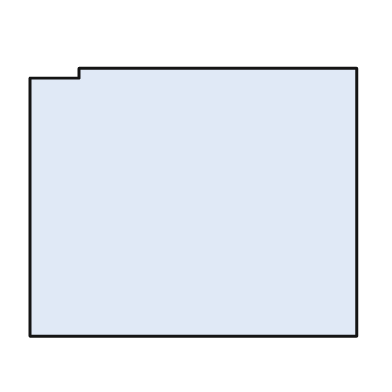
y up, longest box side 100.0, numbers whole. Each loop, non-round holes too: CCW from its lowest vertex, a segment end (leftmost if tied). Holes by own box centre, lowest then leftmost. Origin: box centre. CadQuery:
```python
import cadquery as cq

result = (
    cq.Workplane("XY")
    .moveTo(-50.0, -41.0)
    .lineTo(50.0, -41.0)
    .lineTo(50.0, 41.0)
    .lineTo(-35.0, 41.0)
    .lineTo(-35.0, 38.0)
    .lineTo(-50.0, 38.0)
    .close()
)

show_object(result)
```